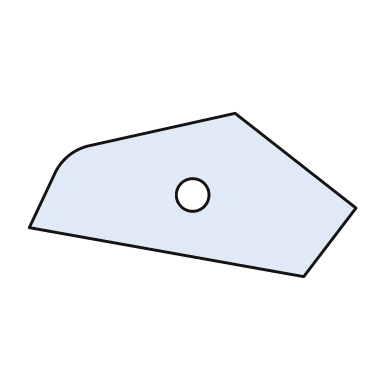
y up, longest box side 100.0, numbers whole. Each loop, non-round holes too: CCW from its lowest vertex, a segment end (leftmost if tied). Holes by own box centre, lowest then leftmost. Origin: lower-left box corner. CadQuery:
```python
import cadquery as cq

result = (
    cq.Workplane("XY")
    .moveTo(84.0, 0.0)
    .lineTo(100.0, 21.0)
    .lineTo(63.0, 50.0)
    .lineTo(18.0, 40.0)
    .threePointArc((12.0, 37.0), (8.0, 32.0))
    .lineTo(0.0, 15.0)
    .close()
    .moveTo(50.0, 25.0)
    .circle(5.0)
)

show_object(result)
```